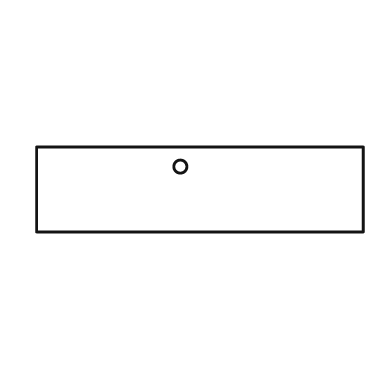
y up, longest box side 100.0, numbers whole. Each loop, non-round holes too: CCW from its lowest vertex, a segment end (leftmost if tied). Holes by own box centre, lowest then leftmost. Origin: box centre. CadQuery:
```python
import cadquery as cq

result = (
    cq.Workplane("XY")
    .moveTo(-50.0, -13.0)
    .lineTo(50.0, -13.0)
    .lineTo(50.0, 13.0)
    .lineTo(-50.0, 13.0)
    .close()
    .moveTo(-6.0, 7.0)
    .circle(2.0)
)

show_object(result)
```